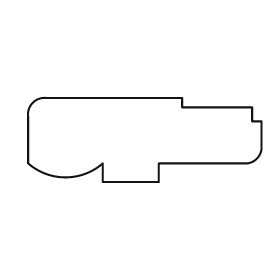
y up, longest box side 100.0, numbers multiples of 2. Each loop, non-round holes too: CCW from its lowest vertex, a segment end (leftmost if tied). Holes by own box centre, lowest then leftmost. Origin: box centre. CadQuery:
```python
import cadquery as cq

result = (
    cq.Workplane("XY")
    .moveTo(-18.0, -18.0)
    .lineTo(6.0, -18.0)
    .lineTo(6.0, -10.0)
    .lineTo(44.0, -10.0)
    .threePointArc((48.0, -8.0), (50.0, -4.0))
    .lineTo(50.0, 8.0)
    .lineTo(46.0, 8.0)
    .lineTo(46.0, 14.0)
    .lineTo(16.0, 14.0)
    .lineTo(16.0, 18.0)
    .lineTo(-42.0, 18.0)
    .threePointArc((-48.0, 16.0), (-50.0, 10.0))
    .lineTo(-50.0, -10.0)
    .threePointArc((-34.0, -16.0), (-18.0, -10.0))
    .close()
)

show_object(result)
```